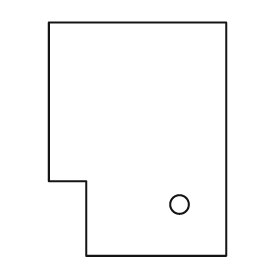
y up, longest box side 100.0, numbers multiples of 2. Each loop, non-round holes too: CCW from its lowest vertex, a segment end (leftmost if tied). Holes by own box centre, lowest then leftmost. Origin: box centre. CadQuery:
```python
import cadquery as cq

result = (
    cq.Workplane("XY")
    .moveTo(-22.0, -50.0)
    .lineTo(38.0, -50.0)
    .lineTo(38.0, 50.0)
    .lineTo(-38.0, 50.0)
    .lineTo(-38.0, -18.0)
    .lineTo(-22.0, -18.0)
    .close()
    .moveTo(18.0, -28.0)
    .circle(4.0)
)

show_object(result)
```